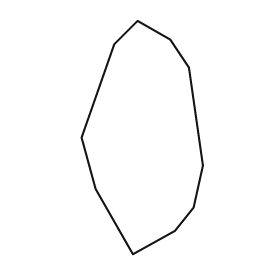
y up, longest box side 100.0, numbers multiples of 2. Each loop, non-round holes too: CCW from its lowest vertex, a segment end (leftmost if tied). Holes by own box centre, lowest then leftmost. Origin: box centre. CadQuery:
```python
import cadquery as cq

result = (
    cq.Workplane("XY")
    .moveTo(-4.0, -50.0)
    .lineTo(14.0, -40.0)
    .lineTo(22.0, -30.0)
    .lineTo(26.0, -12.0)
    .lineTo(20.0, 30.0)
    .lineTo(12.0, 42.0)
    .lineTo(-2.0, 50.0)
    .lineTo(-12.0, 40.0)
    .lineTo(-26.0, 0.0)
    .lineTo(-20.0, -22.0)
    .close()
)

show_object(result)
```